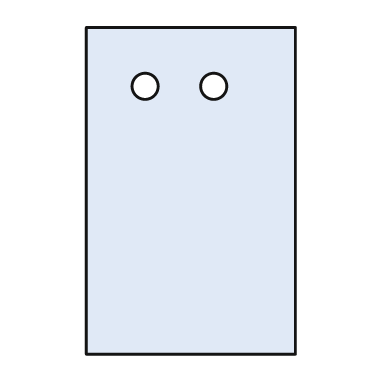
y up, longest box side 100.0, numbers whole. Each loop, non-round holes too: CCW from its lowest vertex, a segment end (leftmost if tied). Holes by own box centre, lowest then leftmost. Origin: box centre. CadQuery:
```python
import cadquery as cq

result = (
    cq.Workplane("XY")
    .moveTo(-32.0, -50.0)
    .lineTo(32.0, -50.0)
    .lineTo(32.0, 50.0)
    .lineTo(-32.0, 50.0)
    .close()
    .moveTo(-14.0, 32.0)
    .circle(4.0)
    .moveTo(7.0, 32.0)
    .circle(4.0)
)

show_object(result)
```